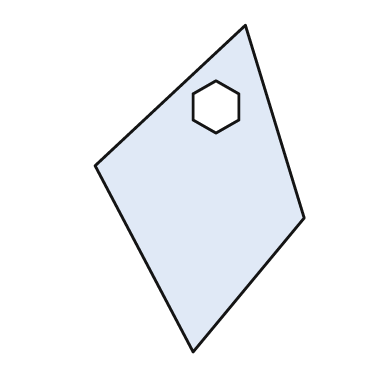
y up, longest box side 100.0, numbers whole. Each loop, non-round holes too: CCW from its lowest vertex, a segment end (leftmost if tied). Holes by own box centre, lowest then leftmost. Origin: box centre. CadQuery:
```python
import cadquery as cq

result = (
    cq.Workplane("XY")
    .moveTo(-2.0, -50.0)
    .lineTo(32.0, -9.0)
    .lineTo(14.0, 50.0)
    .lineTo(-32.0, 7.0)
    .close()
    .moveTo(5.0, 17.0)
    .lineTo(12.0, 21.0)
    .lineTo(12.0, 29.0)
    .lineTo(5.0, 33.0)
    .lineTo(-2.0, 29.0)
    .lineTo(-2.0, 21.0)
    .close()
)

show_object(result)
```